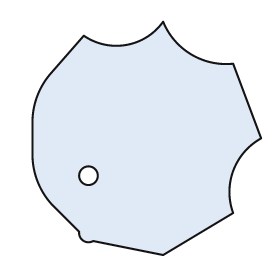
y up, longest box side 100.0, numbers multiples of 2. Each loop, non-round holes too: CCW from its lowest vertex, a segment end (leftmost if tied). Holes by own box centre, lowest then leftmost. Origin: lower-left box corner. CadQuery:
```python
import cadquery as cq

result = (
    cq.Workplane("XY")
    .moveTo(56.0, 0.0)
    .lineTo(86.0, 18.0)
    .threePointArc((86.0, 36.0), (98.0, 50.0))
    .lineTo(86.0, 82.0)
    .threePointArc((68.0, 86.0), (56.0, 100.0))
    .threePointArc((40.0, 90.0), (22.0, 94.0))
    .lineTo(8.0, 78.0)
    .threePointArc((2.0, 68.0), (0.0, 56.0))
    .lineTo(0.0, 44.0)
    .threePointArc((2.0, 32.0), (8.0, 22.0))
    .lineTo(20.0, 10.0)
    .threePointArc((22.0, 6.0), (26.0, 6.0))
    .close()
    .moveTo(24.0, 34.0)
    .circle(4.0)
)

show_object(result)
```